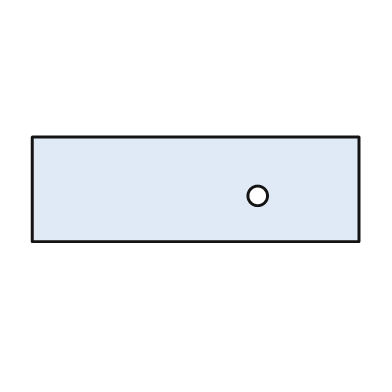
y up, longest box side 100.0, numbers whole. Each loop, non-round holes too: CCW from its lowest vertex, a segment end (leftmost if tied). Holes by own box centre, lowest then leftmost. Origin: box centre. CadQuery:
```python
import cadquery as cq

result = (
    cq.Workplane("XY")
    .moveTo(-50.0, -16.0)
    .lineTo(50.0, -16.0)
    .lineTo(50.0, 16.0)
    .lineTo(-50.0, 16.0)
    .close()
    .moveTo(19.0, -2.0)
    .circle(3.0)
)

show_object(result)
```